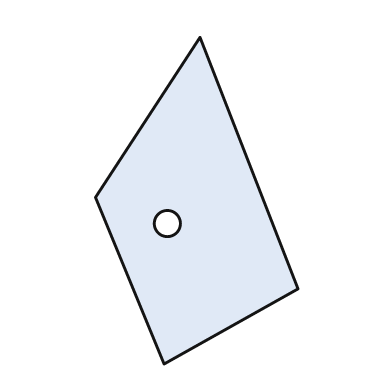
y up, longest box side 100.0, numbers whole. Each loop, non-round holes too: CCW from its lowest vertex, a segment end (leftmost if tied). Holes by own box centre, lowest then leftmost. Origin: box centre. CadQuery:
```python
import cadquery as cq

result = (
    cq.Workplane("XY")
    .moveTo(-10.0, -50.0)
    .lineTo(31.0, -27.0)
    .lineTo(1.0, 50.0)
    .lineTo(-31.0, 1.0)
    .close()
    .moveTo(-9.0, -7.0)
    .circle(4.0)
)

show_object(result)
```